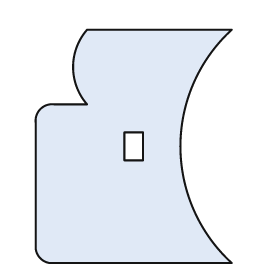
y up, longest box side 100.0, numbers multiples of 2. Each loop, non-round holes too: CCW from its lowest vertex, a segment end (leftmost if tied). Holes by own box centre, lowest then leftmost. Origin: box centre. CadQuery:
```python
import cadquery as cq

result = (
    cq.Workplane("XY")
    .moveTo(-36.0, -50.0)
    .lineTo(42.0, -50.0)
    .threePointArc((20.0, 0.0), (42.0, 50.0))
    .lineTo(-20.0, 50.0)
    .threePointArc((-26.0, 34.0), (-20.0, 18.0))
    .lineTo(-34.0, 18.0)
    .threePointArc((-40.0, 16.0), (-42.0, 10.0))
    .lineTo(-42.0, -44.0)
    .threePointArc((-40.0, -48.0), (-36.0, -50.0))
    .close()
    .moveTo(-4.0, -6.0)
    .lineTo(4.0, -6.0)
    .lineTo(4.0, 6.0)
    .lineTo(-4.0, 6.0)
    .close()
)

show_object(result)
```